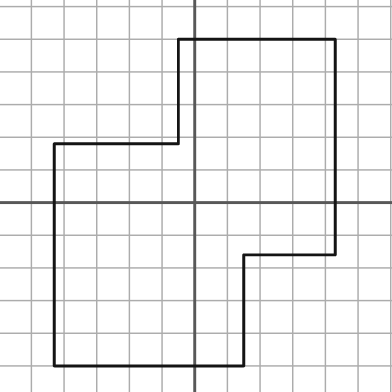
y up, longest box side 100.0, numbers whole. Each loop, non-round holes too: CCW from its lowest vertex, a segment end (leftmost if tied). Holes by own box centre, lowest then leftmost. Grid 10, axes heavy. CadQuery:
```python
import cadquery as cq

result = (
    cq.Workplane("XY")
    .moveTo(-43.0, -50.0)
    .lineTo(15.0, -50.0)
    .lineTo(15.0, -16.0)
    .lineTo(43.0, -16.0)
    .lineTo(43.0, 50.0)
    .lineTo(-5.0, 50.0)
    .lineTo(-5.0, 18.0)
    .lineTo(-43.0, 18.0)
    .close()
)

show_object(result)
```